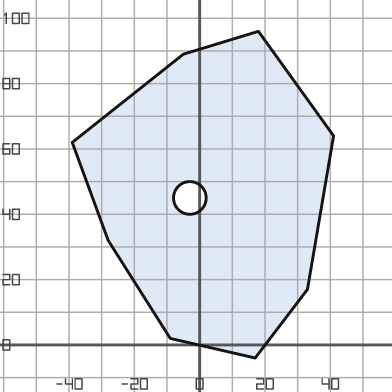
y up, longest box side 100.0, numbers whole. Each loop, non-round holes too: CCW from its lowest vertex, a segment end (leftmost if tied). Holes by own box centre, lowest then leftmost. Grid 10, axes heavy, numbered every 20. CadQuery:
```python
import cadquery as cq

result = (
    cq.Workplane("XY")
    .moveTo(17.0, -4.0)
    .lineTo(33.0, 17.0)
    .lineTo(41.0, 64.0)
    .lineTo(18.0, 96.0)
    .lineTo(-5.0, 89.0)
    .lineTo(-39.0, 62.0)
    .lineTo(-28.0, 32.0)
    .lineTo(-9.0, 2.0)
    .close()
    .moveTo(-3.0, 45.0)
    .circle(5.0)
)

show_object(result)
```